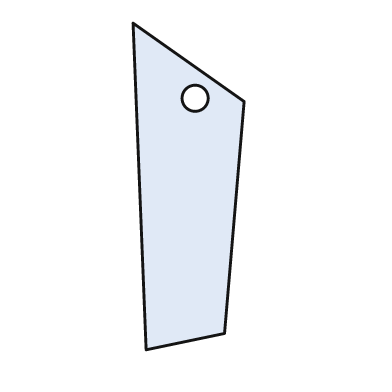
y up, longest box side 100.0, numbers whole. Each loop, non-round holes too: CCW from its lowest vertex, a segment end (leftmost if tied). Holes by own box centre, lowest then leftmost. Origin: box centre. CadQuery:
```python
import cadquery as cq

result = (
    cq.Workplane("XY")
    .moveTo(-13.0, -50.0)
    .lineTo(11.0, -45.0)
    .lineTo(17.0, 26.0)
    .lineTo(-17.0, 50.0)
    .close()
    .moveTo(2.0, 27.0)
    .circle(4.0)
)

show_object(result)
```